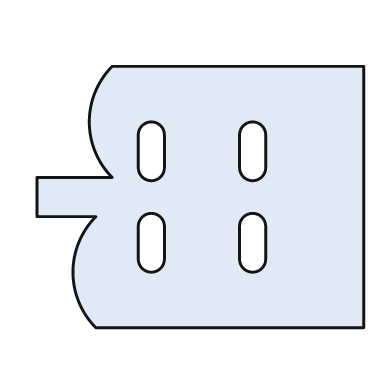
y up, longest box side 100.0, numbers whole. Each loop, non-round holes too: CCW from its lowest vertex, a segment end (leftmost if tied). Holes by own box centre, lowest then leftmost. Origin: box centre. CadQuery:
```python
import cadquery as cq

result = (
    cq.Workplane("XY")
    .moveTo(-32.0, -40.0)
    .lineTo(50.0, -40.0)
    .lineTo(50.0, 40.0)
    .lineTo(-27.0, 40.0)
    .threePointArc((-34.0, 23.0), (-27.0, 6.0))
    .lineTo(-50.0, 6.0)
    .lineTo(-50.0, -6.0)
    .lineTo(-32.0, -6.0)
    .threePointArc((-39.0, -23.0), (-32.0, -40.0))
    .close()
    .moveTo(-19.0, -19.0)
    .threePointArc((-15.0, -23.0), (-11.0, -19.0))
    .lineTo(-11.0, -9.0)
    .threePointArc((-15.0, -5.0), (-19.0, -9.0))
    .close()
    .moveTo(12.0, -19.0)
    .threePointArc((16.0, -23.0), (20.0, -19.0))
    .lineTo(20.0, -9.0)
    .threePointArc((16.0, -5.0), (12.0, -9.0))
    .close()
    .moveTo(-19.0, 9.0)
    .threePointArc((-15.0, 5.0), (-11.0, 9.0))
    .lineTo(-11.0, 19.0)
    .threePointArc((-15.0, 23.0), (-19.0, 19.0))
    .close()
    .moveTo(12.0, 9.0)
    .threePointArc((16.0, 5.0), (20.0, 9.0))
    .lineTo(20.0, 19.0)
    .threePointArc((16.0, 23.0), (12.0, 19.0))
    .close()
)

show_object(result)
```